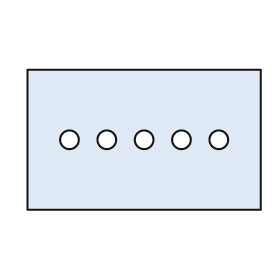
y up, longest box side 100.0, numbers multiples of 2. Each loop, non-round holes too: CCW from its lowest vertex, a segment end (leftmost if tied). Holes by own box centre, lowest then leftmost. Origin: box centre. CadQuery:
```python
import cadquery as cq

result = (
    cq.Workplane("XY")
    .moveTo(-50.0, -30.0)
    .lineTo(50.0, -30.0)
    .lineTo(50.0, 30.0)
    .lineTo(-50.0, 30.0)
    .close()
    .moveTo(-32.0, 0.0)
    .circle(4.0)
    .moveTo(-16.0, 0.0)
    .circle(4.0)
    .moveTo(0.0, 0.0)
    .circle(4.0)
    .moveTo(16.0, 0.0)
    .circle(4.0)
    .moveTo(32.0, 0.0)
    .circle(4.0)
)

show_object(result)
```